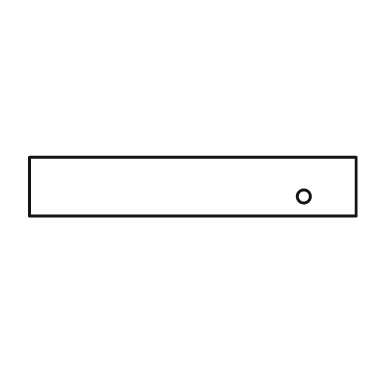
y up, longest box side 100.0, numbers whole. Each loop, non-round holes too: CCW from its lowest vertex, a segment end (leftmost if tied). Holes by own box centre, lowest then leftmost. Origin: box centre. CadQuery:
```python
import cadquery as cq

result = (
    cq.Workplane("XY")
    .moveTo(-50.0, -9.0)
    .lineTo(50.0, -9.0)
    .lineTo(50.0, 9.0)
    .lineTo(-50.0, 9.0)
    .close()
    .moveTo(34.0, -3.0)
    .circle(2.0)
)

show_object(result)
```